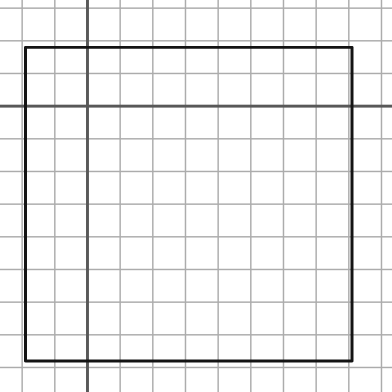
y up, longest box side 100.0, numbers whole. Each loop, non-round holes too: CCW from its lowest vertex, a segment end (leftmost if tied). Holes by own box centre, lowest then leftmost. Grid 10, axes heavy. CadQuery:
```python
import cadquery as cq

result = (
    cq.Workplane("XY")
    .moveTo(-19.0, -78.0)
    .lineTo(81.0, -78.0)
    .lineTo(81.0, 18.0)
    .lineTo(-19.0, 18.0)
    .close()
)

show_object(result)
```